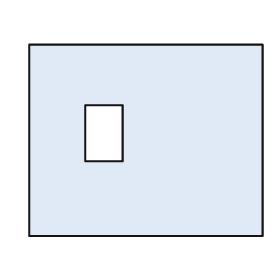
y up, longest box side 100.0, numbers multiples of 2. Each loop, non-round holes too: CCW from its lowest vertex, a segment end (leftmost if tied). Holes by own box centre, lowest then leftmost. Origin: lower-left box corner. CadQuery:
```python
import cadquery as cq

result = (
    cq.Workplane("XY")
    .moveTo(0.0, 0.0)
    .lineTo(100.0, 0.0)
    .lineTo(100.0, 82.0)
    .lineTo(0.0, 82.0)
    .close()
    .moveTo(24.0, 32.0)
    .lineTo(40.0, 32.0)
    .lineTo(40.0, 56.0)
    .lineTo(24.0, 56.0)
    .close()
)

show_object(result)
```